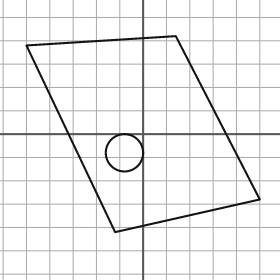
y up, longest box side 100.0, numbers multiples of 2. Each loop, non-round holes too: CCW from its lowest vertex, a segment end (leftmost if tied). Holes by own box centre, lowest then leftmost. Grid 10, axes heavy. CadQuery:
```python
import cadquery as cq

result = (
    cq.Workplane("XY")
    .moveTo(-12.0, -42.0)
    .lineTo(50.0, -28.0)
    .lineTo(14.0, 42.0)
    .lineTo(-50.0, 38.0)
    .close()
    .moveTo(-8.0, -8.0)
    .circle(8.0)
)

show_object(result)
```